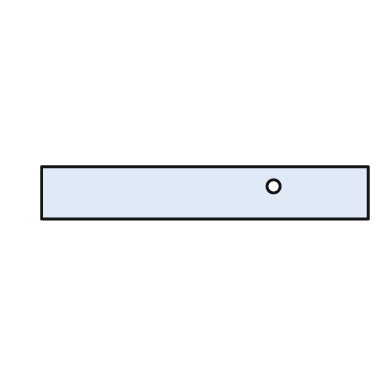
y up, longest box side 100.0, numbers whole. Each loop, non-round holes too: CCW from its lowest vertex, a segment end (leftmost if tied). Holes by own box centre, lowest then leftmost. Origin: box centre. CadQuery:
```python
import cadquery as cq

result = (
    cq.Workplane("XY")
    .moveTo(-50.0, -8.0)
    .lineTo(50.0, -8.0)
    .lineTo(50.0, 8.0)
    .lineTo(-50.0, 8.0)
    .close()
    .moveTo(21.0, 2.0)
    .circle(2.0)
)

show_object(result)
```